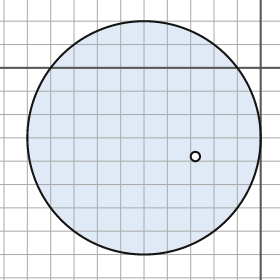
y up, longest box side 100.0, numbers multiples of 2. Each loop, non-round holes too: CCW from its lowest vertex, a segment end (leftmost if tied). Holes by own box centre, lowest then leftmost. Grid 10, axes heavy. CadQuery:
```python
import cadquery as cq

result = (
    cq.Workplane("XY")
    .moveTo(-50.0, -30.0)
    .circle(50.0)
    .moveTo(-28.0, -38.0)
    .circle(2.0)
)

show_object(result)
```